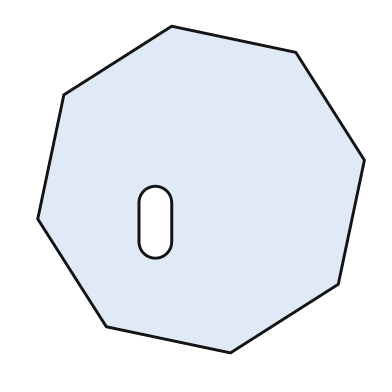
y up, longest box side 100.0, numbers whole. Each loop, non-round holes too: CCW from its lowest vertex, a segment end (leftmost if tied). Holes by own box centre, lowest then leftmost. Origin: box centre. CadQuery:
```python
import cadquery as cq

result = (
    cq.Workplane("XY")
    .moveTo(9.0, -50.0)
    .lineTo(42.0, -29.0)
    .lineTo(50.0, 9.0)
    .lineTo(29.0, 42.0)
    .lineTo(-9.0, 50.0)
    .lineTo(-42.0, 29.0)
    .lineTo(-50.0, -9.0)
    .lineTo(-29.0, -42.0)
    .close()
    .moveTo(-19.0, -16.0)
    .threePointArc((-14.0, -21.0), (-9.0, -16.0))
    .lineTo(-9.0, -4.0)
    .threePointArc((-14.0, 1.0), (-19.0, -4.0))
    .close()
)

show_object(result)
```